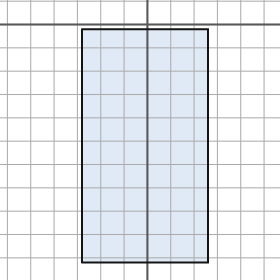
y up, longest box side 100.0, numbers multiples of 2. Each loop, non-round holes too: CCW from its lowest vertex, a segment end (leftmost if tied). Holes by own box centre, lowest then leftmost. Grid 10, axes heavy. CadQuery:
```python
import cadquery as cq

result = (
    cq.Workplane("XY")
    .moveTo(-28.0, -102.0)
    .lineTo(26.0, -102.0)
    .lineTo(26.0, -2.0)
    .lineTo(-28.0, -2.0)
    .close()
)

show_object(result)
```